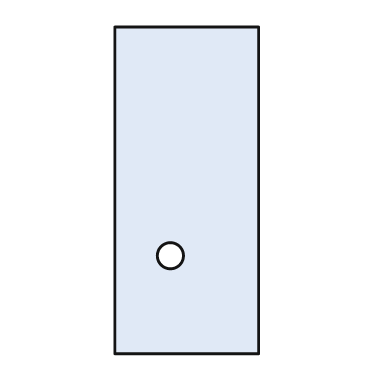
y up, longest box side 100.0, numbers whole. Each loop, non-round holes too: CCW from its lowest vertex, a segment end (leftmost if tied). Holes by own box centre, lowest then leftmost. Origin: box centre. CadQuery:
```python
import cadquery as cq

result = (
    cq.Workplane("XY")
    .moveTo(-22.0, -50.0)
    .lineTo(22.0, -50.0)
    .lineTo(22.0, 50.0)
    .lineTo(-22.0, 50.0)
    .close()
    .moveTo(-5.0, -20.0)
    .circle(4.0)
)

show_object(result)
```